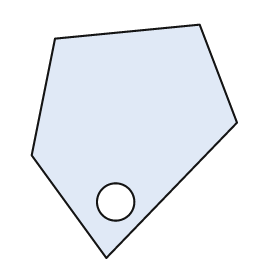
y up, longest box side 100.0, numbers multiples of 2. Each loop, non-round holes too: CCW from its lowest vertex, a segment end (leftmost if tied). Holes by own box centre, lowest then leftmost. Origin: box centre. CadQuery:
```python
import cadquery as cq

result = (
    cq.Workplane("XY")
    .moveTo(-12.0, -50.0)
    .lineTo(44.0, 8.0)
    .lineTo(28.0, 50.0)
    .lineTo(-34.0, 44.0)
    .lineTo(-44.0, -6.0)
    .close()
    .moveTo(-8.0, -26.0)
    .circle(8.0)
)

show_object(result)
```